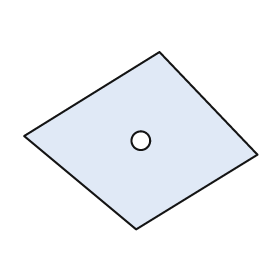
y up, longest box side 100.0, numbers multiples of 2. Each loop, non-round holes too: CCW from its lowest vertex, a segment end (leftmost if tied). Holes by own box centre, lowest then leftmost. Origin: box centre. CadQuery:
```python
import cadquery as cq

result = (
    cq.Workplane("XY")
    .moveTo(-2.0, -38.0)
    .lineTo(50.0, -6.0)
    .lineTo(8.0, 38.0)
    .lineTo(-50.0, 2.0)
    .close()
    .moveTo(0.0, 0.0)
    .circle(4.0)
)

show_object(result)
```